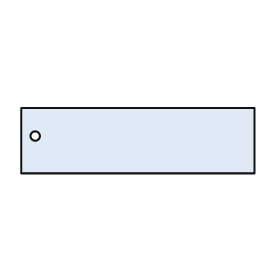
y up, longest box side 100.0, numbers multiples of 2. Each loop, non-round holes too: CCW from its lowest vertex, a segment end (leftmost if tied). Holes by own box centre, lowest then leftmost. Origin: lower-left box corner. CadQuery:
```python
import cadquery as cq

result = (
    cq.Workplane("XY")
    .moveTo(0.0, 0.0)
    .lineTo(100.0, 0.0)
    .lineTo(100.0, 28.0)
    .lineTo(0.0, 28.0)
    .close()
    .moveTo(6.0, 16.0)
    .circle(2.0)
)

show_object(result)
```